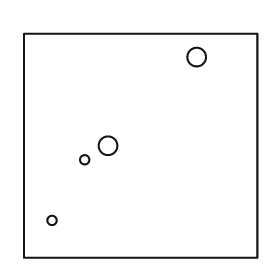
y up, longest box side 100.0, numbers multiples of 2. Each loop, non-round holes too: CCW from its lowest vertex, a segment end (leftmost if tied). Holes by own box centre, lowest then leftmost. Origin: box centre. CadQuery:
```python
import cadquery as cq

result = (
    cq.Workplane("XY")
    .moveTo(-50.0, -48.0)
    .lineTo(50.0, -48.0)
    .lineTo(50.0, 48.0)
    .lineTo(-50.0, 48.0)
    .close()
    .moveTo(-38.0, -32.0)
    .circle(2.0)
    .moveTo(-24.0, -6.0)
    .circle(2.0)
    .moveTo(-14.0, 0.0)
    .circle(4.0)
    .moveTo(24.0, 38.0)
    .circle(4.0)
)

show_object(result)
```